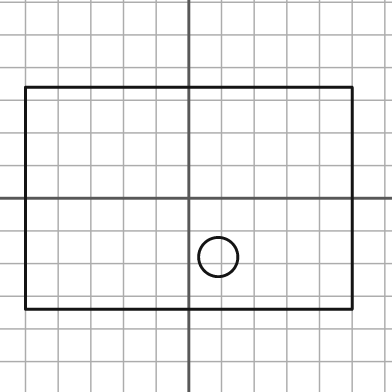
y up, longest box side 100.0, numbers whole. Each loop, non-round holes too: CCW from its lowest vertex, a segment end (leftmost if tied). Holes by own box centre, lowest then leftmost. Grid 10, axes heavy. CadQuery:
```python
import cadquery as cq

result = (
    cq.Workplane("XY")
    .moveTo(-50.0, -34.0)
    .lineTo(50.0, -34.0)
    .lineTo(50.0, 34.0)
    .lineTo(-50.0, 34.0)
    .close()
    .moveTo(9.0, -18.0)
    .circle(6.0)
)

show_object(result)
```